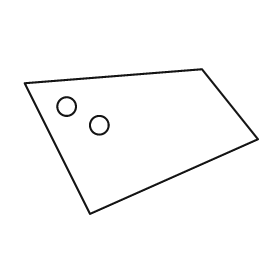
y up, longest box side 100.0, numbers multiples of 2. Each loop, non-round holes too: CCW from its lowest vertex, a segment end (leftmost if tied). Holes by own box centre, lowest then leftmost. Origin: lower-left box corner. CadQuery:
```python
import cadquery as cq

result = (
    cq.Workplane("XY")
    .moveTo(28.0, 0.0)
    .lineTo(100.0, 32.0)
    .lineTo(76.0, 62.0)
    .lineTo(0.0, 56.0)
    .close()
    .moveTo(32.0, 38.0)
    .circle(4.0)
    .moveTo(18.0, 46.0)
    .circle(4.0)
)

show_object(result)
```